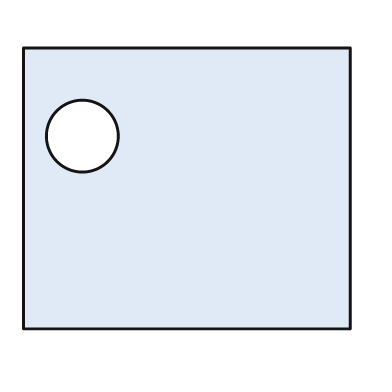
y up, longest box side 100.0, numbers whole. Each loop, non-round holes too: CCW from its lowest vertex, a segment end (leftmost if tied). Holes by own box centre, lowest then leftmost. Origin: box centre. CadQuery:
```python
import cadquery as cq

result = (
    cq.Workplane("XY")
    .moveTo(-50.0, -43.0)
    .lineTo(50.0, -43.0)
    .lineTo(50.0, 43.0)
    .lineTo(-50.0, 43.0)
    .close()
    .moveTo(-32.0, 16.0)
    .circle(11.0)
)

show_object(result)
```